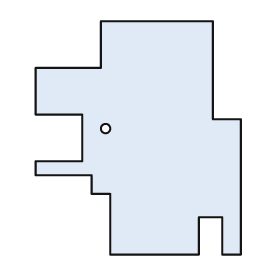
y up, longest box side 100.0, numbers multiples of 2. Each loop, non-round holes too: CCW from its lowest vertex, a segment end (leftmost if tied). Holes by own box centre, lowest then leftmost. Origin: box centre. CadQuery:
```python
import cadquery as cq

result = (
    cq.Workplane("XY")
    .moveTo(-12.0, -50.0)
    .lineTo(26.0, -50.0)
    .lineTo(26.0, -34.0)
    .lineTo(36.0, -34.0)
    .lineTo(36.0, -50.0)
    .lineTo(44.0, -50.0)
    .lineTo(44.0, 8.0)
    .lineTo(32.0, 8.0)
    .lineTo(32.0, 50.0)
    .lineTo(-16.0, 50.0)
    .lineTo(-16.0, 30.0)
    .lineTo(-44.0, 30.0)
    .lineTo(-44.0, 10.0)
    .lineTo(-24.0, 10.0)
    .lineTo(-24.0, -10.0)
    .lineTo(-44.0, -10.0)
    .lineTo(-44.0, -16.0)
    .lineTo(-20.0, -16.0)
    .lineTo(-20.0, -24.0)
    .lineTo(-12.0, -24.0)
    .close()
    .moveTo(-14.0, 4.0)
    .circle(2.0)
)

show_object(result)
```